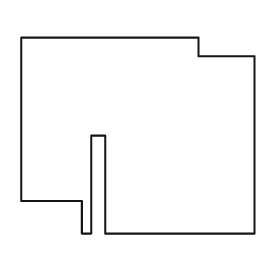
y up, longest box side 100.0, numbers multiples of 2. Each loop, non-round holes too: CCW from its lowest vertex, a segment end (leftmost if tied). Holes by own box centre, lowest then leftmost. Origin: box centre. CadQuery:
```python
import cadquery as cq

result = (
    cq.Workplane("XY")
    .moveTo(-24.0, -42.0)
    .lineTo(-20.0, -42.0)
    .lineTo(-20.0, 0.0)
    .lineTo(-14.0, 0.0)
    .lineTo(-14.0, -42.0)
    .lineTo(50.0, -42.0)
    .lineTo(50.0, 34.0)
    .lineTo(26.0, 34.0)
    .lineTo(26.0, 42.0)
    .lineTo(-50.0, 42.0)
    .lineTo(-50.0, -28.0)
    .lineTo(-24.0, -28.0)
    .close()
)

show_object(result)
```